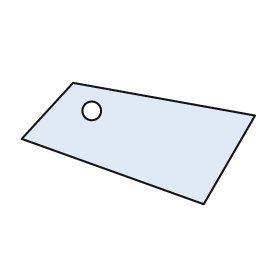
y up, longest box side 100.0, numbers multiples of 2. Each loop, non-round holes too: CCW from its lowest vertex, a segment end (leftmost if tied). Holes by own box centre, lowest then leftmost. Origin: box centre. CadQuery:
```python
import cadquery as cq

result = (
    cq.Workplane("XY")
    .moveTo(28.0, -26.0)
    .lineTo(50.0, 12.0)
    .lineTo(-28.0, 26.0)
    .lineTo(-50.0, 2.0)
    .close()
    .moveTo(-20.0, 14.0)
    .circle(4.0)
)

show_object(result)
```